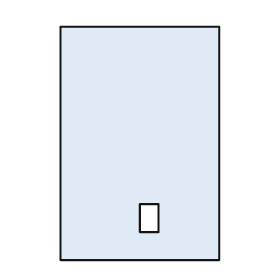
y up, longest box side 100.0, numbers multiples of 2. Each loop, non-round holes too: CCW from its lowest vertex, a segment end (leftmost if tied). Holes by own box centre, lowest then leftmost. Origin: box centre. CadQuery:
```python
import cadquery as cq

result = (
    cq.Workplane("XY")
    .moveTo(-34.0, -50.0)
    .lineTo(34.0, -50.0)
    .lineTo(34.0, 50.0)
    .lineTo(-34.0, 50.0)
    .close()
    .moveTo(0.0, -38.0)
    .lineTo(8.0, -38.0)
    .lineTo(8.0, -26.0)
    .lineTo(0.0, -26.0)
    .close()
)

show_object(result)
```